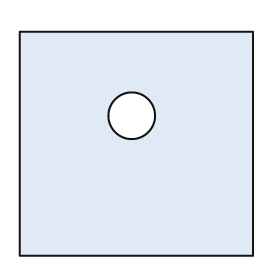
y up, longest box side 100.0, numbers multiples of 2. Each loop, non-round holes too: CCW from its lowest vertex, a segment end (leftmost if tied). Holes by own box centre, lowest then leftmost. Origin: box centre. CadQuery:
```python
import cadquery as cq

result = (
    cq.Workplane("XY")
    .moveTo(-50.0, -48.0)
    .lineTo(50.0, -48.0)
    .lineTo(50.0, 48.0)
    .lineTo(-50.0, 48.0)
    .close()
    .moveTo(-2.0, 12.0)
    .circle(10.0)
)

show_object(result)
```